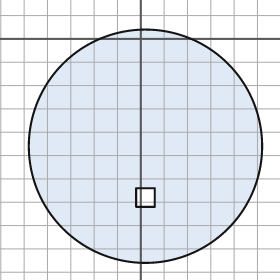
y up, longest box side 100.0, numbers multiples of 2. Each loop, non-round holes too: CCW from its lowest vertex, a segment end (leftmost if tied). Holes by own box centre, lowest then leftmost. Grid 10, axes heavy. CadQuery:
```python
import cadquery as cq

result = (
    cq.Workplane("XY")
    .moveTo(2.0, -46.0)
    .circle(50.0)
    .moveTo(-2.0, -72.0)
    .lineTo(6.0, -72.0)
    .lineTo(6.0, -64.0)
    .lineTo(-2.0, -64.0)
    .close()
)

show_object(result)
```